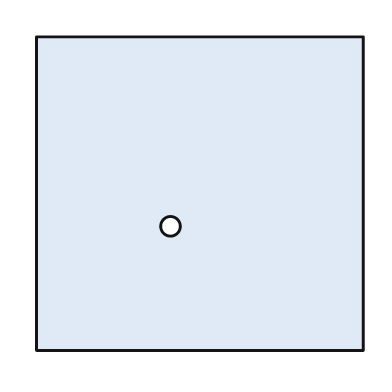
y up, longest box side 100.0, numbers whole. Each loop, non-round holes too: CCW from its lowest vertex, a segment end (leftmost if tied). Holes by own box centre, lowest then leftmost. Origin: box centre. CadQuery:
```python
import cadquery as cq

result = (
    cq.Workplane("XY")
    .moveTo(-50.0, -48.0)
    .lineTo(50.0, -48.0)
    .lineTo(50.0, 48.0)
    .lineTo(-50.0, 48.0)
    .close()
    .moveTo(-9.0, -10.0)
    .circle(3.0)
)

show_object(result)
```